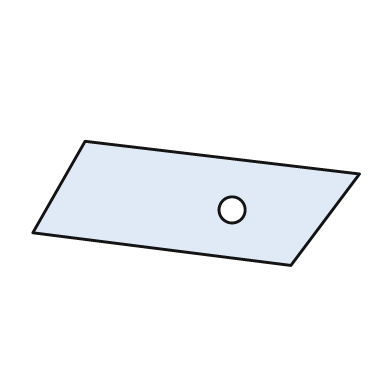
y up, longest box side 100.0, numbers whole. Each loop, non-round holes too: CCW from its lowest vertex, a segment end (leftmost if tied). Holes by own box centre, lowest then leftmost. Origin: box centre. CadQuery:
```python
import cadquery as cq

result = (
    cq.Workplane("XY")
    .moveTo(29.0, -19.0)
    .lineTo(50.0, 9.0)
    .lineTo(-34.0, 19.0)
    .lineTo(-50.0, -9.0)
    .close()
    .moveTo(11.0, -2.0)
    .circle(4.0)
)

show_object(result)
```